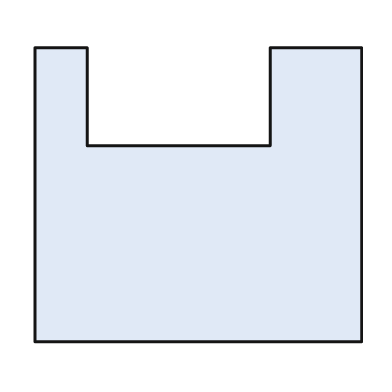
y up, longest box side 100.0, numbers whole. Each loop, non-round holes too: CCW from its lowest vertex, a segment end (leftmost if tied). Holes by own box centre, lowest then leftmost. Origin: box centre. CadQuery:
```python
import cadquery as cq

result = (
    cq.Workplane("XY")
    .moveTo(-50.0, -45.0)
    .lineTo(50.0, -45.0)
    .lineTo(50.0, 45.0)
    .lineTo(22.0, 45.0)
    .lineTo(22.0, 15.0)
    .lineTo(-34.0, 15.0)
    .lineTo(-34.0, 45.0)
    .lineTo(-50.0, 45.0)
    .close()
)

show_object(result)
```